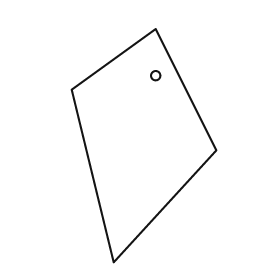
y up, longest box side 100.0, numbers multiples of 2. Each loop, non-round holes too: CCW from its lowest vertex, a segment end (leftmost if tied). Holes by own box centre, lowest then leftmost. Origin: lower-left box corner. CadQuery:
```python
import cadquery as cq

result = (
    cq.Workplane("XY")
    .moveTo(18.0, 0.0)
    .lineTo(62.0, 48.0)
    .lineTo(36.0, 100.0)
    .lineTo(0.0, 74.0)
    .close()
    .moveTo(36.0, 80.0)
    .circle(2.0)
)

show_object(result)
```